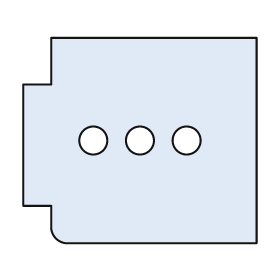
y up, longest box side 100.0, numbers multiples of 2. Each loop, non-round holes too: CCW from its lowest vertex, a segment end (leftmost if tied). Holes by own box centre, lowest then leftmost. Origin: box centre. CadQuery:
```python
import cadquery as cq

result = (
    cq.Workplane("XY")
    .moveTo(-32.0, -44.0)
    .lineTo(50.0, -44.0)
    .lineTo(50.0, 44.0)
    .lineTo(-38.0, 44.0)
    .lineTo(-38.0, 24.0)
    .lineTo(-50.0, 24.0)
    .lineTo(-50.0, -28.0)
    .lineTo(-38.0, -28.0)
    .lineTo(-38.0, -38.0)
    .threePointArc((-36.0, -42.0), (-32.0, -44.0))
    .close()
    .moveTo(-20.0, 0.0)
    .circle(6.0)
    .moveTo(0.0, 0.0)
    .circle(6.0)
    .moveTo(20.0, 0.0)
    .circle(6.0)
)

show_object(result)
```